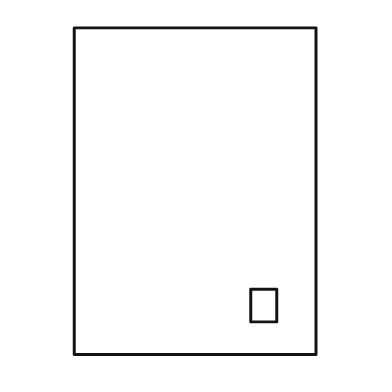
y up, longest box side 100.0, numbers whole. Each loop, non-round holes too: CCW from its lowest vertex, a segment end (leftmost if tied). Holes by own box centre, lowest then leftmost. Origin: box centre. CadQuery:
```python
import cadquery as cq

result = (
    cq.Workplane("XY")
    .moveTo(-37.0, -50.0)
    .lineTo(37.0, -50.0)
    .lineTo(37.0, 50.0)
    .lineTo(-37.0, 50.0)
    .close()
    .moveTo(17.0, -40.0)
    .lineTo(25.0, -40.0)
    .lineTo(25.0, -30.0)
    .lineTo(17.0, -30.0)
    .close()
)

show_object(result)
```